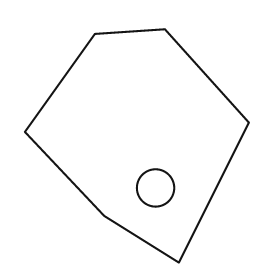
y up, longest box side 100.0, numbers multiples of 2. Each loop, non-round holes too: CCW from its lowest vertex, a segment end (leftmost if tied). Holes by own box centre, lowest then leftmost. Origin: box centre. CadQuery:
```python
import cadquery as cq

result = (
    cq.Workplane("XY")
    .moveTo(18.0, -50.0)
    .lineTo(48.0, 10.0)
    .lineTo(12.0, 50.0)
    .lineTo(-18.0, 48.0)
    .lineTo(-48.0, 6.0)
    .lineTo(-14.0, -30.0)
    .close()
    .moveTo(8.0, -18.0)
    .circle(8.0)
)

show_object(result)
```